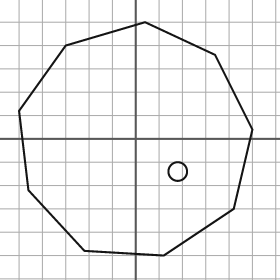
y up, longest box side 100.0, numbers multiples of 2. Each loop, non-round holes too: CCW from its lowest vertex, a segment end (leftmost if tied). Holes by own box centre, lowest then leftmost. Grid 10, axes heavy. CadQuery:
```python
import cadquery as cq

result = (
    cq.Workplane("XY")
    .moveTo(12.0, -50.0)
    .lineTo(42.0, -30.0)
    .lineTo(50.0, 4.0)
    .lineTo(34.0, 36.0)
    .lineTo(4.0, 50.0)
    .lineTo(-30.0, 40.0)
    .lineTo(-50.0, 12.0)
    .lineTo(-46.0, -22.0)
    .lineTo(-22.0, -48.0)
    .close()
    .moveTo(18.0, -14.0)
    .circle(4.0)
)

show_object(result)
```